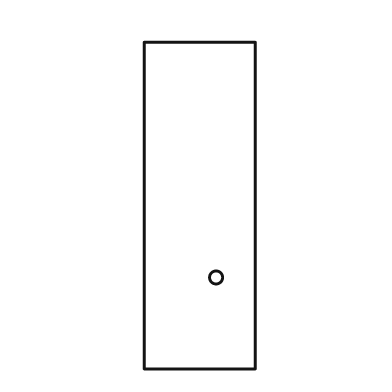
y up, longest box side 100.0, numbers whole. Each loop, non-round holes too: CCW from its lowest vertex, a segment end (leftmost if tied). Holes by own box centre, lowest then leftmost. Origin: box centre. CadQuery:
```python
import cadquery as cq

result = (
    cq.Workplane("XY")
    .moveTo(-17.0, -50.0)
    .lineTo(17.0, -50.0)
    .lineTo(17.0, 50.0)
    .lineTo(-17.0, 50.0)
    .close()
    .moveTo(5.0, -22.0)
    .circle(2.0)
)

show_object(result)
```